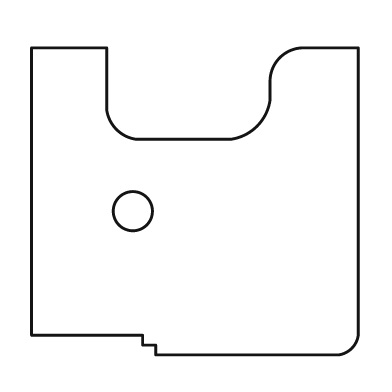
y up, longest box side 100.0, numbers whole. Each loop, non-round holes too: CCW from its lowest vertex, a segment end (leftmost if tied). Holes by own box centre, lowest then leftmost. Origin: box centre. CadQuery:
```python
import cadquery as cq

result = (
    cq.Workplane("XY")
    .moveTo(-12.0, -47.0)
    .lineTo(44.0, -47.0)
    .threePointArc((48.0, -45.0), (50.0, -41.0))
    .lineTo(50.0, 47.0)
    .lineTo(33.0, 47.0)
    .threePointArc((26.0, 44.0), (23.0, 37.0))
    .lineTo(23.0, 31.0)
    .threePointArc((19.0, 23.0), (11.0, 19.0))
    .lineTo(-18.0, 19.0)
    .threePointArc((-24.0, 22.0), (-27.0, 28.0))
    .lineTo(-27.0, 47.0)
    .lineTo(-50.0, 47.0)
    .lineTo(-50.0, -41.0)
    .lineTo(-16.0, -41.0)
    .lineTo(-16.0, -44.0)
    .lineTo(-12.0, -44.0)
    .close()
    .moveTo(-19.0, -3.0)
    .circle(6.0)
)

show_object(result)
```